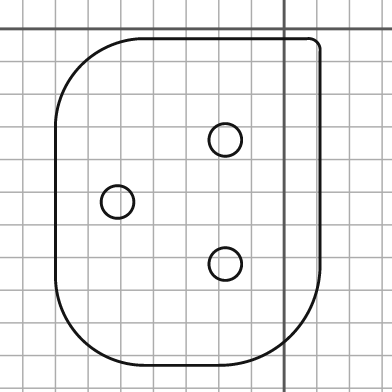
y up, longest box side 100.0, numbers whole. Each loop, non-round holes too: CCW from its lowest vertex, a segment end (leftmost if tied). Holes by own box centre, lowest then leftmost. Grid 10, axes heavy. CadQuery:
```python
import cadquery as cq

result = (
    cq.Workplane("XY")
    .moveTo(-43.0, -103.0)
    .lineTo(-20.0, -103.0)
    .threePointArc((2.0, -94.0), (11.0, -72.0))
    .lineTo(11.0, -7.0)
    .threePointArc((10.0, -4.0), (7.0, -3.0))
    .lineTo(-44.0, -3.0)
    .threePointArc((-62.0, -11.0), (-70.0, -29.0))
    .lineTo(-70.0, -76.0)
    .threePointArc((-62.0, -95.0), (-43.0, -103.0))
    .close()
    .moveTo(-18.0, -72.0)
    .circle(5.0)
    .moveTo(-51.0, -53.0)
    .circle(5.0)
    .moveTo(-18.0, -34.0)
    .circle(5.0)
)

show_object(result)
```